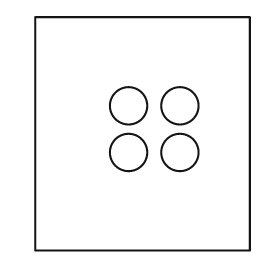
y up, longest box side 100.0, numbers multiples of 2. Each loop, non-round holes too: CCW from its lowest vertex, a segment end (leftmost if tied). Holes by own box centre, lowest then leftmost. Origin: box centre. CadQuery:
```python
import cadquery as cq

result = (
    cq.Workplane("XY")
    .moveTo(-46.0, -50.0)
    .lineTo(46.0, -50.0)
    .lineTo(46.0, 50.0)
    .lineTo(-46.0, 50.0)
    .close()
    .moveTo(-6.0, -8.0)
    .circle(8.0)
    .moveTo(16.0, -8.0)
    .circle(8.0)
    .moveTo(-6.0, 12.0)
    .circle(8.0)
    .moveTo(16.0, 12.0)
    .circle(8.0)
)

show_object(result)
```